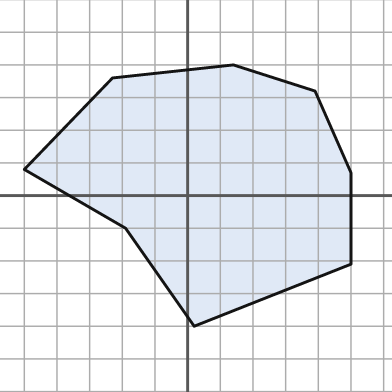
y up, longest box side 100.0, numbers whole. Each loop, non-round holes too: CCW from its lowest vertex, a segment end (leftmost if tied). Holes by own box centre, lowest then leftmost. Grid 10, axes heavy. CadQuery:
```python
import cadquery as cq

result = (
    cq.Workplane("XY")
    .moveTo(2.0, -40.0)
    .lineTo(50.0, -21.0)
    .lineTo(50.0, 7.0)
    .lineTo(39.0, 32.0)
    .lineTo(14.0, 40.0)
    .lineTo(-23.0, 36.0)
    .lineTo(-50.0, 8.0)
    .lineTo(-19.0, -10.0)
    .close()
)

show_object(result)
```